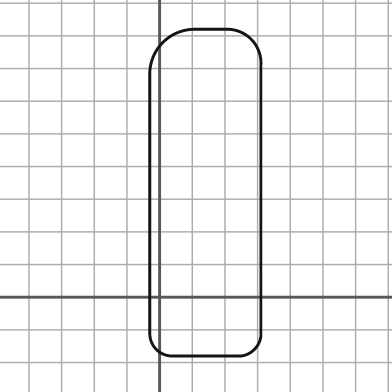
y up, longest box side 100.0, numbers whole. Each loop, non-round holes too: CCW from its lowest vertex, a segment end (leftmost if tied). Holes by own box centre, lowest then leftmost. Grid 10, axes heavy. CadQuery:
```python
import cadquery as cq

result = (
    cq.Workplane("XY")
    .moveTo(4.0, -18.0)
    .lineTo(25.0, -18.0)
    .threePointArc((29.0, -16.0), (31.0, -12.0))
    .lineTo(31.0, 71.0)
    .threePointArc((28.0, 79.0), (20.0, 82.0))
    .lineTo(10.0, 82.0)
    .threePointArc((1.0, 78.0), (-3.0, 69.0))
    .lineTo(-3.0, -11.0)
    .threePointArc((-1.0, -16.0), (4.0, -18.0))
    .close()
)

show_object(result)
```